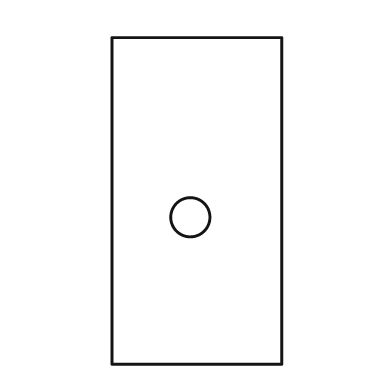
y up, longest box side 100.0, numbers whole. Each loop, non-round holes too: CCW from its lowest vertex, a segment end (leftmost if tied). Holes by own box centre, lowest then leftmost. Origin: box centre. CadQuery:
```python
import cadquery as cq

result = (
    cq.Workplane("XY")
    .moveTo(-26.0, -50.0)
    .lineTo(26.0, -50.0)
    .lineTo(26.0, 50.0)
    .lineTo(-26.0, 50.0)
    .close()
    .moveTo(-2.0, -5.0)
    .circle(6.0)
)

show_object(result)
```